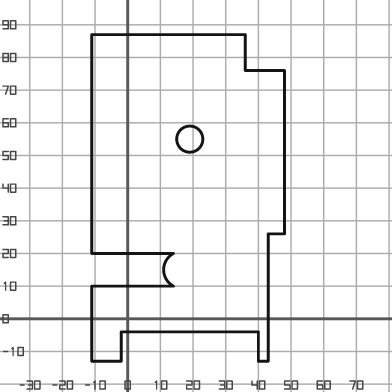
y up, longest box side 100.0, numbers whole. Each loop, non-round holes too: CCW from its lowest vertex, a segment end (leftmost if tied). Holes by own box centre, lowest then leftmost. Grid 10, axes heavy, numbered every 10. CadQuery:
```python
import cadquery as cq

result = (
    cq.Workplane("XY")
    .moveTo(-11.0, -13.0)
    .lineTo(-2.0, -13.0)
    .lineTo(-2.0, -4.0)
    .lineTo(40.0, -4.0)
    .lineTo(40.0, -13.0)
    .lineTo(43.0, -13.0)
    .lineTo(43.0, 26.0)
    .lineTo(48.0, 26.0)
    .lineTo(48.0, 76.0)
    .lineTo(36.0, 76.0)
    .lineTo(36.0, 87.0)
    .lineTo(-11.0, 87.0)
    .lineTo(-11.0, 20.0)
    .lineTo(14.0, 20.0)
    .threePointArc((11.0, 15.0), (14.0, 10.0))
    .lineTo(-11.0, 10.0)
    .close()
    .moveTo(19.0, 55.0)
    .circle(4.0)
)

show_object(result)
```